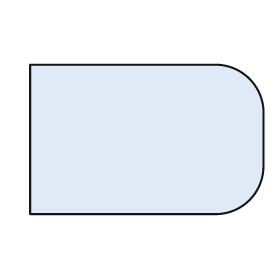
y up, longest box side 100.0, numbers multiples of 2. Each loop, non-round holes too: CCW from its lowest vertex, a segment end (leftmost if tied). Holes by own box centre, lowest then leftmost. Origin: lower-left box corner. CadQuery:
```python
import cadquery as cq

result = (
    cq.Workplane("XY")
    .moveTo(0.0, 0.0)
    .lineTo(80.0, 0.0)
    .threePointArc((94.0, 6.0), (100.0, 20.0))
    .lineTo(100.0, 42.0)
    .threePointArc((94.0, 58.0), (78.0, 64.0))
    .lineTo(0.0, 64.0)
    .close()
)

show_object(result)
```